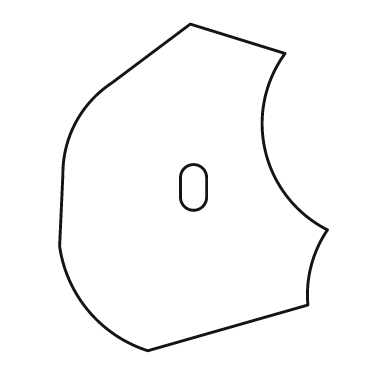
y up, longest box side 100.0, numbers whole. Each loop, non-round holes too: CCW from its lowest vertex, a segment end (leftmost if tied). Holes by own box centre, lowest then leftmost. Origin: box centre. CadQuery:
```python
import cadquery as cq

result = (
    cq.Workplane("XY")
    .moveTo(-14.0, -50.0)
    .lineTo(35.0, -36.0)
    .threePointArc((36.0, -24.0), (41.0, -13.0))
    .threePointArc((22.0, 11.0), (28.0, 41.0))
    .lineTo(-1.0, 50.0)
    .lineTo(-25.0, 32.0)
    .threePointArc((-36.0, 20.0), (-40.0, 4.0))
    .lineTo(-41.0, -18.0)
    .threePointArc((-32.0, -38.0), (-14.0, -50.0))
    .close()
    .moveTo(-4.0, -3.0)
    .threePointArc((0.0, -7.0), (4.0, -3.0))
    .lineTo(4.0, 3.0)
    .threePointArc((0.0, 7.0), (-4.0, 3.0))
    .close()
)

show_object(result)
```